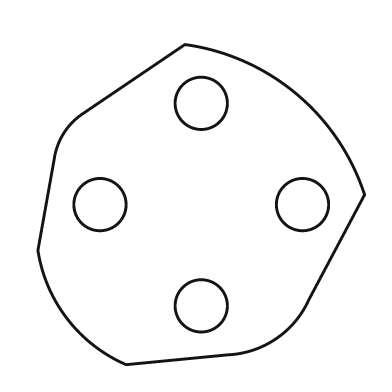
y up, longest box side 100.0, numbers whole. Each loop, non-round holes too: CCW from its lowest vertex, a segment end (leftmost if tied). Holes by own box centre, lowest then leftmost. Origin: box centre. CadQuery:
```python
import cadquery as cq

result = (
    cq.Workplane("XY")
    .moveTo(-23.0, -49.0)
    .lineTo(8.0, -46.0)
    .threePointArc((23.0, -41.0), (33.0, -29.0))
    .lineTo(50.0, 3.0)
    .threePointArc((29.0, 34.0), (-5.0, 49.0))
    .lineTo(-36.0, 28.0)
    .threePointArc((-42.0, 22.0), (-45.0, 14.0))
    .lineTo(-50.0, -14.0)
    .threePointArc((-41.0, -35.0), (-23.0, -49.0))
    .close()
    .moveTo(0.0, -31.0)
    .circle(8.0)
    .moveTo(-31.0, 0.0)
    .circle(8.0)
    .moveTo(31.0, 0.0)
    .circle(8.0)
    .moveTo(0.0, 31.0)
    .circle(8.0)
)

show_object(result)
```